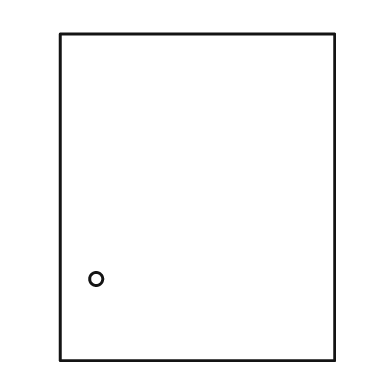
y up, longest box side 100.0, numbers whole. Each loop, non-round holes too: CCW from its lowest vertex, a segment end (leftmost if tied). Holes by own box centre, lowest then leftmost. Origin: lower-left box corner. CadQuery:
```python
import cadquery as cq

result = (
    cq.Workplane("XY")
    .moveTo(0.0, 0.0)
    .lineTo(84.0, 0.0)
    .lineTo(84.0, 100.0)
    .lineTo(0.0, 100.0)
    .close()
    .moveTo(11.0, 25.0)
    .circle(2.0)
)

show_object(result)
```